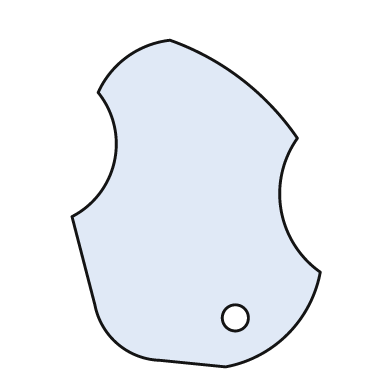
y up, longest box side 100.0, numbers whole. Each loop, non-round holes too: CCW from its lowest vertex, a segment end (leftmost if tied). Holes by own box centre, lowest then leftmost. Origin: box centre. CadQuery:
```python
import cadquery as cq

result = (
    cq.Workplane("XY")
    .moveTo(9.0, -50.0)
    .threePointArc((28.0, -40.0), (38.0, -21.0))
    .threePointArc((26.0, -2.0), (31.0, 20.0))
    .threePointArc((14.0, 38.0), (-8.0, 50.0))
    .threePointArc((-21.0, 45.0), (-30.0, 34.0))
    .threePointArc((-25.0, 13.0), (-38.0, -4.0))
    .lineTo(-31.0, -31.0)
    .threePointArc((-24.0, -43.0), (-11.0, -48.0))
    .close()
    .moveTo(12.0, -35.0)
    .circle(4.0)
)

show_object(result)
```